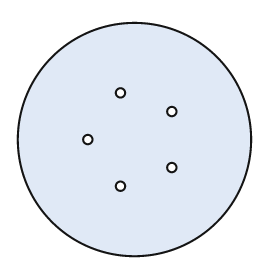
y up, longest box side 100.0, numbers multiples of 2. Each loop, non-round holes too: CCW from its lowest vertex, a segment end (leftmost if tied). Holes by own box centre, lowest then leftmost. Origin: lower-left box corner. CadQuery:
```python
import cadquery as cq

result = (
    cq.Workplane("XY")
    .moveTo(50.0, 50.0)
    .circle(50.0)
    .moveTo(44.0, 30.0)
    .circle(2.0)
    .moveTo(66.0, 38.0)
    .circle(2.0)
    .moveTo(30.0, 50.0)
    .circle(2.0)
    .moveTo(66.0, 62.0)
    .circle(2.0)
    .moveTo(44.0, 70.0)
    .circle(2.0)
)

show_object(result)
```